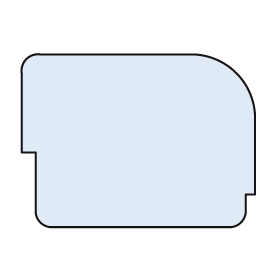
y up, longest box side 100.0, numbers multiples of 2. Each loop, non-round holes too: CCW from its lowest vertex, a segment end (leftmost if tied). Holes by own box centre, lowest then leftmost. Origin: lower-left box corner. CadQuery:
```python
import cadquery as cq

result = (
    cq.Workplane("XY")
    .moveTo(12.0, 0.0)
    .lineTo(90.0, 0.0)
    .threePointArc((94.0, 2.0), (96.0, 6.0))
    .lineTo(96.0, 14.0)
    .lineTo(100.0, 14.0)
    .lineTo(100.0, 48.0)
    .threePointArc((92.0, 66.0), (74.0, 74.0))
    .lineTo(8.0, 74.0)
    .threePointArc((2.0, 72.0), (0.0, 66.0))
    .lineTo(0.0, 32.0)
    .lineTo(6.0, 32.0)
    .lineTo(6.0, 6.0)
    .threePointArc((8.0, 2.0), (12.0, 0.0))
    .close()
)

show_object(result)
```